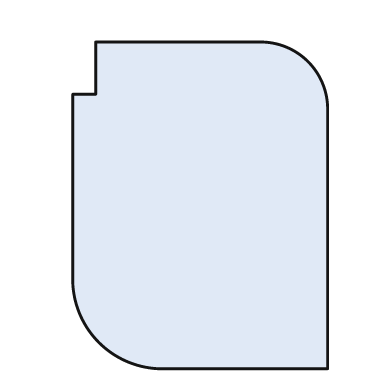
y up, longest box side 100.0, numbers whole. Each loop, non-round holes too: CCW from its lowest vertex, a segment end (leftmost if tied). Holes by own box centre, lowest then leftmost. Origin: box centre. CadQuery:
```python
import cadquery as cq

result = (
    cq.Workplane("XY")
    .moveTo(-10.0, -50.0)
    .lineTo(39.0, -50.0)
    .lineTo(39.0, 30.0)
    .threePointArc((33.0, 44.0), (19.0, 50.0))
    .lineTo(-32.0, 50.0)
    .lineTo(-32.0, 34.0)
    .lineTo(-39.0, 34.0)
    .lineTo(-39.0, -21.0)
    .threePointArc((-31.0, -42.0), (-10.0, -50.0))
    .close()
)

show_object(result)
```